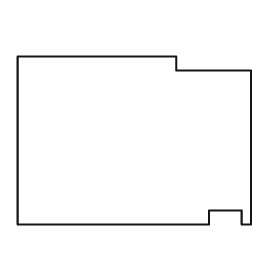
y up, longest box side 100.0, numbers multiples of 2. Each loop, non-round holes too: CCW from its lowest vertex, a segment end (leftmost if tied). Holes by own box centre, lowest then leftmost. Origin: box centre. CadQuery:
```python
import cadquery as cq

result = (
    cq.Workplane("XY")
    .moveTo(-50.0, -36.0)
    .lineTo(32.0, -36.0)
    .lineTo(32.0, -30.0)
    .lineTo(46.0, -30.0)
    .lineTo(46.0, -36.0)
    .lineTo(50.0, -36.0)
    .lineTo(50.0, 30.0)
    .lineTo(18.0, 30.0)
    .lineTo(18.0, 36.0)
    .lineTo(-50.0, 36.0)
    .close()
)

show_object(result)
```